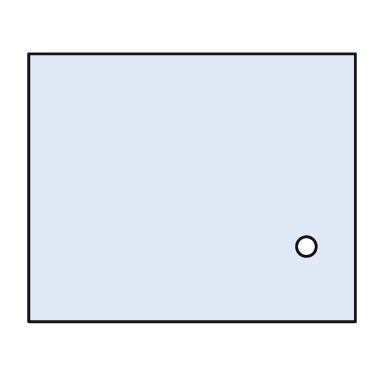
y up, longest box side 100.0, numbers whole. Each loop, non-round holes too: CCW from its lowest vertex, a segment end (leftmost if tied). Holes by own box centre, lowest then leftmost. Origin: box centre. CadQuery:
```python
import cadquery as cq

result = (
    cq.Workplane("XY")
    .moveTo(-50.0, -41.0)
    .lineTo(50.0, -41.0)
    .lineTo(50.0, 41.0)
    .lineTo(-50.0, 41.0)
    .close()
    .moveTo(35.0, -18.0)
    .circle(3.0)
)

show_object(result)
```